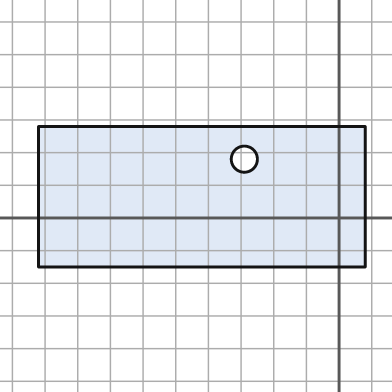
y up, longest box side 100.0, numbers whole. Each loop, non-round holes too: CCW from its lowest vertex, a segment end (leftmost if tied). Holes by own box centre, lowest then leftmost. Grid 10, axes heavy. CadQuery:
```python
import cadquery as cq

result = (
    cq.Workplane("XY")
    .moveTo(-92.0, -15.0)
    .lineTo(8.0, -15.0)
    .lineTo(8.0, 28.0)
    .lineTo(-92.0, 28.0)
    .close()
    .moveTo(-29.0, 18.0)
    .circle(4.0)
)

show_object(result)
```